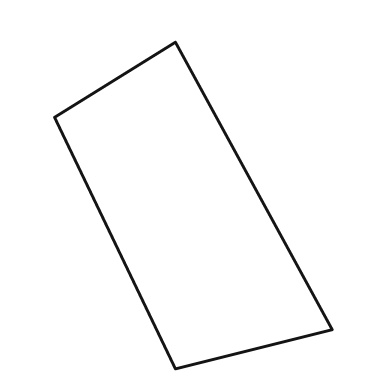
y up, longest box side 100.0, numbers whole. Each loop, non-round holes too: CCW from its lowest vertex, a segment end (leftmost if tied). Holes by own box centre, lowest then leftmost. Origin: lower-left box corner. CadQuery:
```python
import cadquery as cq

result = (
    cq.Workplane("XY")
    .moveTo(37.0, 0.0)
    .lineTo(85.0, 12.0)
    .lineTo(37.0, 100.0)
    .lineTo(0.0, 77.0)
    .close()
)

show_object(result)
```